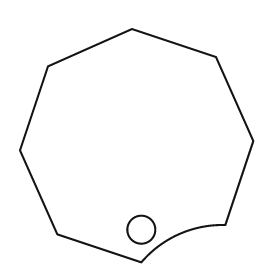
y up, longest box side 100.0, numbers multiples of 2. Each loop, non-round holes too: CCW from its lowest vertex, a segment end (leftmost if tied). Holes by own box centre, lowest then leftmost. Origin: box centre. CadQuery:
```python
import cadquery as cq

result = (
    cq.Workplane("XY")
    .moveTo(2.0, -50.0)
    .threePointArc((18.0, -38.0), (38.0, -34.0))
    .lineTo(50.0, 2.0)
    .lineTo(34.0, 38.0)
    .lineTo(-2.0, 50.0)
    .lineTo(-38.0, 34.0)
    .lineTo(-50.0, -2.0)
    .lineTo(-34.0, -38.0)
    .close()
    .moveTo(2.0, -36.0)
    .circle(6.0)
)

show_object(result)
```